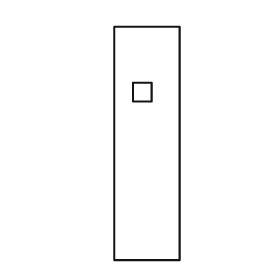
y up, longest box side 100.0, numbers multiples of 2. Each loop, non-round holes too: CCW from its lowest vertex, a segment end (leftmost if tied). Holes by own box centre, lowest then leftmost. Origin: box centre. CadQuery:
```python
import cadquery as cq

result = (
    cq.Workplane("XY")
    .moveTo(-14.0, -50.0)
    .lineTo(14.0, -50.0)
    .lineTo(14.0, 50.0)
    .lineTo(-14.0, 50.0)
    .close()
    .moveTo(-6.0, 18.0)
    .lineTo(2.0, 18.0)
    .lineTo(2.0, 26.0)
    .lineTo(-6.0, 26.0)
    .close()
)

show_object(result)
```